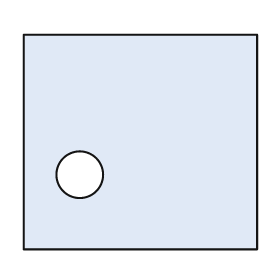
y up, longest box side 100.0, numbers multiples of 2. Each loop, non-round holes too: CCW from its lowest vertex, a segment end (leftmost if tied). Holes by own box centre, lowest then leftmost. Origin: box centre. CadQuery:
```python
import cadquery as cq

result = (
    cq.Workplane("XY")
    .moveTo(-50.0, -46.0)
    .lineTo(50.0, -46.0)
    .lineTo(50.0, 46.0)
    .lineTo(-50.0, 46.0)
    .close()
    .moveTo(-26.0, -14.0)
    .circle(10.0)
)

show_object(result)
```